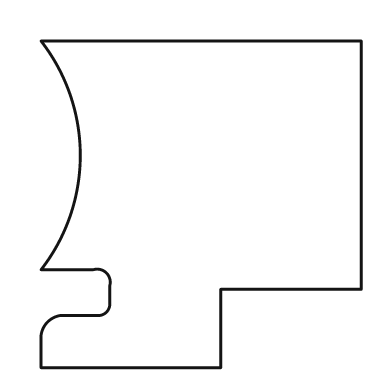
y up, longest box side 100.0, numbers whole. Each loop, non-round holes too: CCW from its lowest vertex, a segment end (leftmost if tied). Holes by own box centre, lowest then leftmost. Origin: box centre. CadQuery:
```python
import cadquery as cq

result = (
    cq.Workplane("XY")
    .moveTo(-49.0, -50.0)
    .lineTo(6.0, -50.0)
    .lineTo(6.0, -26.0)
    .lineTo(49.0, -26.0)
    .lineTo(49.0, 50.0)
    .lineTo(-49.0, 50.0)
    .threePointArc((-37.0, 15.0), (-49.0, -20.0))
    .lineTo(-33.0, -20.0)
    .threePointArc((-29.0, -21.0), (-28.0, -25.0))
    .lineTo(-28.0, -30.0)
    .threePointArc((-29.0, -33.0), (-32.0, -34.0))
    .lineTo(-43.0, -34.0)
    .threePointArc((-47.0, -36.0), (-49.0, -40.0))
    .close()
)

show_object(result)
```